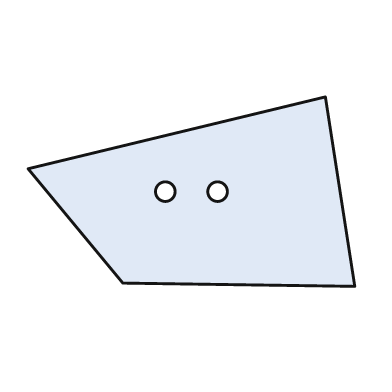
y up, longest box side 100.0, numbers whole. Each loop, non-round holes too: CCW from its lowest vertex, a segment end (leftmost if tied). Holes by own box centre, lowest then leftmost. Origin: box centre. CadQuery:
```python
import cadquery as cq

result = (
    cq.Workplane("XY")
    .moveTo(50.0, -29.0)
    .lineTo(41.0, 29.0)
    .lineTo(-50.0, 7.0)
    .lineTo(-21.0, -28.0)
    .close()
    .moveTo(-8.0, 0.0)
    .circle(3.0)
    .moveTo(8.0, 0.0)
    .circle(3.0)
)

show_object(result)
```